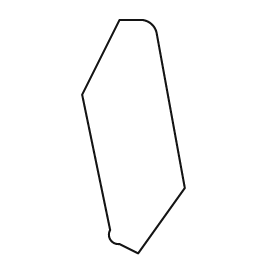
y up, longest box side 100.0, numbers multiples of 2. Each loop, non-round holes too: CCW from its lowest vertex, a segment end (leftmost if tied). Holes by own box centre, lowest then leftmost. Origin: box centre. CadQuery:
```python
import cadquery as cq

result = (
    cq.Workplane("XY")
    .moveTo(2.0, -50.0)
    .lineTo(22.0, -22.0)
    .lineTo(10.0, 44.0)
    .threePointArc((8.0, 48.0), (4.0, 50.0))
    .lineTo(-6.0, 50.0)
    .lineTo(-22.0, 18.0)
    .lineTo(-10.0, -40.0)
    .threePointArc((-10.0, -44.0), (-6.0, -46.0))
    .close()
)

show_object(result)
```